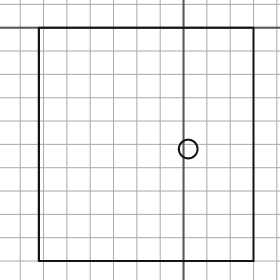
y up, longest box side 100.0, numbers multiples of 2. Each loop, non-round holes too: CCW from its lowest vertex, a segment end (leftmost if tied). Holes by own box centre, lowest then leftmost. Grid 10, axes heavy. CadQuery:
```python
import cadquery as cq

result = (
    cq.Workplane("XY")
    .moveTo(-62.0, -100.0)
    .lineTo(30.0, -100.0)
    .lineTo(30.0, 0.0)
    .lineTo(-62.0, 0.0)
    .close()
    .moveTo(2.0, -52.0)
    .circle(4.0)
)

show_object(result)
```